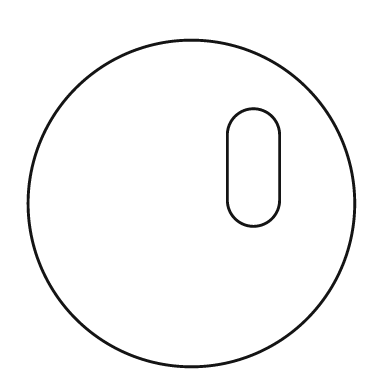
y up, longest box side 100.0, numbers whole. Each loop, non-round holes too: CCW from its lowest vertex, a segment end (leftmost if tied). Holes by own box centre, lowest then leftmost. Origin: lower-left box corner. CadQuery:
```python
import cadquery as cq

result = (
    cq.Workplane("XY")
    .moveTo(50.0, 50.0)
    .circle(50.0)
    .moveTo(61.0, 51.0)
    .threePointArc((69.0, 43.0), (77.0, 51.0))
    .lineTo(77.0, 71.0)
    .threePointArc((69.0, 79.0), (61.0, 71.0))
    .close()
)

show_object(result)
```